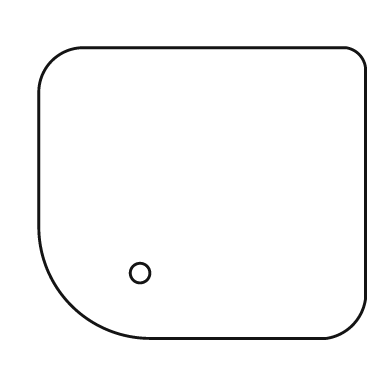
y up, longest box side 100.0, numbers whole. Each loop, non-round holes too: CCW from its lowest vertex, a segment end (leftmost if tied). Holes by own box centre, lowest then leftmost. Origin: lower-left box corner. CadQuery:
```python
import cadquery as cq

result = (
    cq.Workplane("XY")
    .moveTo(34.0, 0.0)
    .lineTo(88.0, 0.0)
    .threePointArc((96.0, 4.0), (100.0, 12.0))
    .lineTo(100.0, 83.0)
    .threePointArc((98.0, 87.0), (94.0, 89.0))
    .lineTo(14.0, 89.0)
    .threePointArc((4.0, 85.0), (0.0, 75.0))
    .lineTo(0.0, 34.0)
    .threePointArc((10.0, 10.0), (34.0, 0.0))
    .close()
    .moveTo(31.0, 20.0)
    .circle(3.0)
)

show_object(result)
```